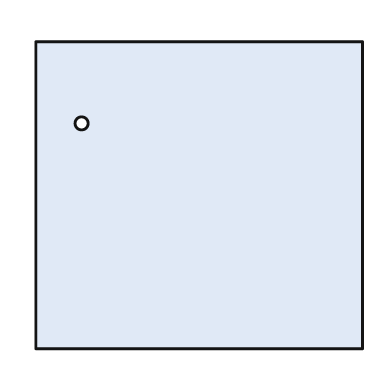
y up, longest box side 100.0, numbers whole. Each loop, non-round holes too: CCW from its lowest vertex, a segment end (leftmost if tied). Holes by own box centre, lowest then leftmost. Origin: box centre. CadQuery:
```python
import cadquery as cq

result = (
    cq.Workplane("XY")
    .moveTo(-50.0, -47.0)
    .lineTo(50.0, -47.0)
    .lineTo(50.0, 47.0)
    .lineTo(-50.0, 47.0)
    .close()
    .moveTo(-36.0, 22.0)
    .circle(2.0)
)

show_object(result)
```